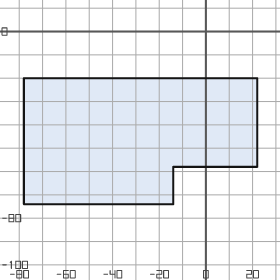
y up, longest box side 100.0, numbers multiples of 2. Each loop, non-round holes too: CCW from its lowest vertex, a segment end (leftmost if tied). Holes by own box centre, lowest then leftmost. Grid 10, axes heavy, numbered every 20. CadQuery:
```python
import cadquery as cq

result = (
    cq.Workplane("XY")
    .moveTo(-78.0, -74.0)
    .lineTo(-14.0, -74.0)
    .lineTo(-14.0, -58.0)
    .lineTo(22.0, -58.0)
    .lineTo(22.0, -20.0)
    .lineTo(-78.0, -20.0)
    .close()
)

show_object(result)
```